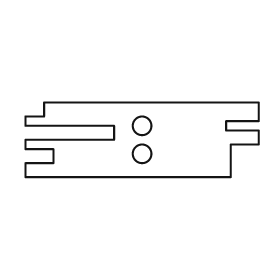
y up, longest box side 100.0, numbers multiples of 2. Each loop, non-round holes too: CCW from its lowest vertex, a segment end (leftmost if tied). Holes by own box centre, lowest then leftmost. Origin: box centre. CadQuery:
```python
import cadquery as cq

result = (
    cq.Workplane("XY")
    .moveTo(-50.0, -16.0)
    .lineTo(38.0, -16.0)
    .lineTo(38.0, -2.0)
    .lineTo(50.0, -2.0)
    .lineTo(50.0, 4.0)
    .lineTo(36.0, 4.0)
    .lineTo(36.0, 8.0)
    .lineTo(50.0, 8.0)
    .lineTo(50.0, 16.0)
    .lineTo(-42.0, 16.0)
    .lineTo(-42.0, 10.0)
    .lineTo(-50.0, 10.0)
    .lineTo(-50.0, 6.0)
    .lineTo(-12.0, 6.0)
    .lineTo(-12.0, 0.0)
    .lineTo(-50.0, 0.0)
    .lineTo(-50.0, -4.0)
    .lineTo(-38.0, -4.0)
    .lineTo(-38.0, -10.0)
    .lineTo(-50.0, -10.0)
    .close()
    .moveTo(0.0, -6.0)
    .circle(4.0)
    .moveTo(0.0, 6.0)
    .circle(4.0)
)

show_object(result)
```